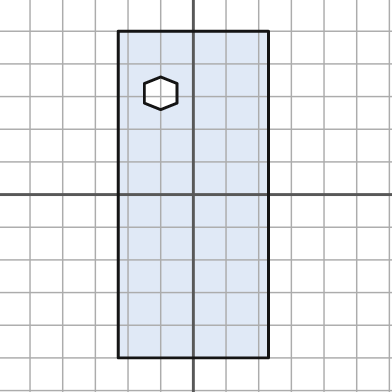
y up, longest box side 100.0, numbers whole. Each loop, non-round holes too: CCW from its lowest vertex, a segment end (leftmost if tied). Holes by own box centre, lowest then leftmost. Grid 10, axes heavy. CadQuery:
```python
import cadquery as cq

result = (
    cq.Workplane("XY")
    .moveTo(-23.0, -50.0)
    .lineTo(23.0, -50.0)
    .lineTo(23.0, 50.0)
    .lineTo(-23.0, 50.0)
    .close()
    .moveTo(-10.0, 26.0)
    .lineTo(-5.0, 28.0)
    .lineTo(-5.0, 34.0)
    .lineTo(-10.0, 36.0)
    .lineTo(-15.0, 34.0)
    .lineTo(-15.0, 28.0)
    .close()
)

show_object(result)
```